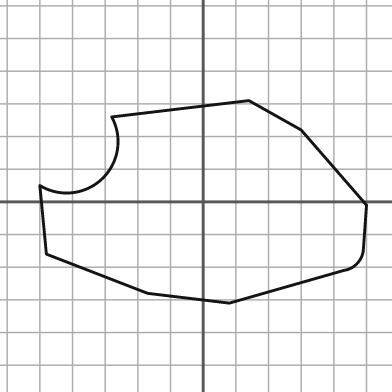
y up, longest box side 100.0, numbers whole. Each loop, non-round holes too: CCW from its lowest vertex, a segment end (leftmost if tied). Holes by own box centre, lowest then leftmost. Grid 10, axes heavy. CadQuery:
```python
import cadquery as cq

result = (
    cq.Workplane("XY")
    .moveTo(8.0, -31.0)
    .lineTo(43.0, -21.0)
    .threePointArc((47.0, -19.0), (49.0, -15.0))
    .lineTo(50.0, -1.0)
    .lineTo(30.0, 22.0)
    .lineTo(14.0, 31.0)
    .lineTo(-28.0, 26.0)
    .threePointArc((-31.0, 7.0), (-50.0, 5.0))
    .lineTo(-48.0, -16.0)
    .lineTo(-17.0, -28.0)
    .close()
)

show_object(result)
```